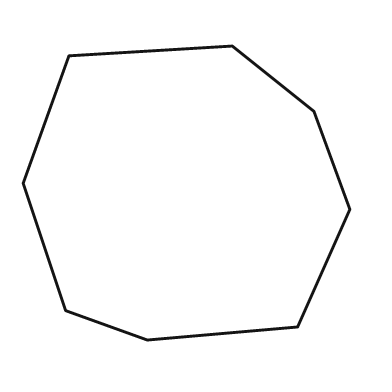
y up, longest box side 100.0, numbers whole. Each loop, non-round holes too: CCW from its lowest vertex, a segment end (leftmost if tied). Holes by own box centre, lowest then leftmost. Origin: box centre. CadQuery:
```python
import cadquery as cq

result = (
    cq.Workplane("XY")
    .moveTo(-12.0, -45.0)
    .lineTo(34.0, -41.0)
    .lineTo(50.0, -5.0)
    .lineTo(39.0, 25.0)
    .lineTo(14.0, 45.0)
    .lineTo(-36.0, 42.0)
    .lineTo(-50.0, 3.0)
    .lineTo(-37.0, -36.0)
    .close()
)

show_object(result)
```